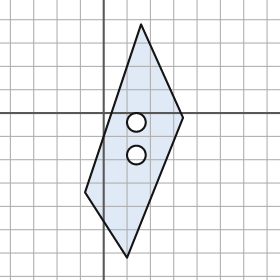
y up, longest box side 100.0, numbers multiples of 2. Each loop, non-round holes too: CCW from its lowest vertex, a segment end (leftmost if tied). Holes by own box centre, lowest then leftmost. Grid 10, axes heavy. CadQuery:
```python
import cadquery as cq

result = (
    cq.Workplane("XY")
    .moveTo(10.0, -62.0)
    .lineTo(34.0, -2.0)
    .lineTo(16.0, 38.0)
    .lineTo(-8.0, -34.0)
    .close()
    .moveTo(14.0, -18.0)
    .circle(4.0)
    .moveTo(14.0, -4.0)
    .circle(4.0)
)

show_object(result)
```